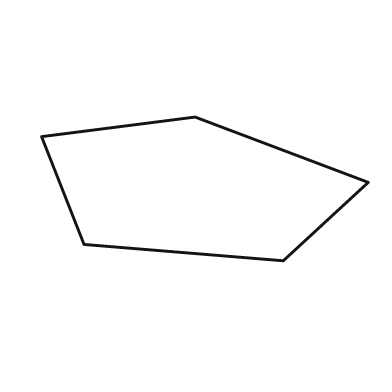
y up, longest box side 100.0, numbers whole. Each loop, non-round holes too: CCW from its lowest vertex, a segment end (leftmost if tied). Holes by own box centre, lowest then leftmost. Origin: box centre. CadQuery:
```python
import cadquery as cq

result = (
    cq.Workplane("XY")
    .moveTo(24.0, -22.0)
    .lineTo(50.0, 2.0)
    .lineTo(-3.0, 22.0)
    .lineTo(-50.0, 16.0)
    .lineTo(-37.0, -17.0)
    .close()
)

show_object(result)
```